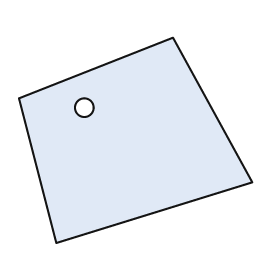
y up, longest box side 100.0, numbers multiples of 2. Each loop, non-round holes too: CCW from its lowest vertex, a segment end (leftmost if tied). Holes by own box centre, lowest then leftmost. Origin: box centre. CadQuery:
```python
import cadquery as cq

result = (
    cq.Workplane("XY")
    .moveTo(-34.0, -44.0)
    .lineTo(50.0, -18.0)
    .lineTo(16.0, 44.0)
    .lineTo(-50.0, 18.0)
    .close()
    .moveTo(-22.0, 14.0)
    .circle(4.0)
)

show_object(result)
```